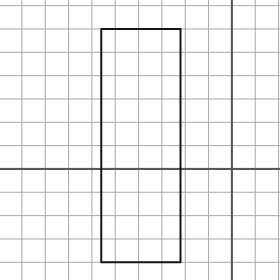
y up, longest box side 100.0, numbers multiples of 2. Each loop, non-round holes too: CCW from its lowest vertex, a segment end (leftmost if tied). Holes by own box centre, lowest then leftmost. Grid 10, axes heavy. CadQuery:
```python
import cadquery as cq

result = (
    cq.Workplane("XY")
    .moveTo(-56.0, -40.0)
    .lineTo(-22.0, -40.0)
    .lineTo(-22.0, 60.0)
    .lineTo(-56.0, 60.0)
    .close()
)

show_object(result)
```